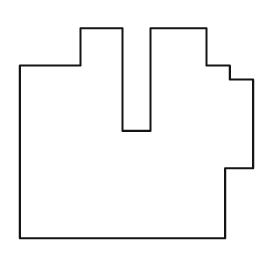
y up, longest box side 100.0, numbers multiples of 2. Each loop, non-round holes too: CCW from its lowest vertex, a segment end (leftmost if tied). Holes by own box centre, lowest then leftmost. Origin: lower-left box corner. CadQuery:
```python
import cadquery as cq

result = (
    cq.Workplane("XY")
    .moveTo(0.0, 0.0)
    .lineTo(88.0, 0.0)
    .lineTo(88.0, 30.0)
    .lineTo(100.0, 30.0)
    .lineTo(100.0, 68.0)
    .lineTo(90.0, 68.0)
    .lineTo(90.0, 74.0)
    .lineTo(80.0, 74.0)
    .lineTo(80.0, 90.0)
    .lineTo(56.0, 90.0)
    .lineTo(56.0, 46.0)
    .lineTo(44.0, 46.0)
    .lineTo(44.0, 90.0)
    .lineTo(26.0, 90.0)
    .lineTo(26.0, 74.0)
    .lineTo(0.0, 74.0)
    .close()
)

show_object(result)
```